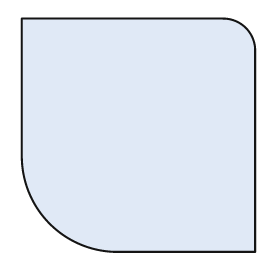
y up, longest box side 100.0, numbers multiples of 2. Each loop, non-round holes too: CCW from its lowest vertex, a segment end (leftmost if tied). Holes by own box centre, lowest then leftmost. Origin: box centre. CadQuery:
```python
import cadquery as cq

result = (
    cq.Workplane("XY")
    .moveTo(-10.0, -50.0)
    .lineTo(50.0, -50.0)
    .lineTo(50.0, 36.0)
    .threePointArc((46.0, 46.0), (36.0, 50.0))
    .lineTo(-50.0, 50.0)
    .lineTo(-50.0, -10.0)
    .threePointArc((-38.0, -38.0), (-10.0, -50.0))
    .close()
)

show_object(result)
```